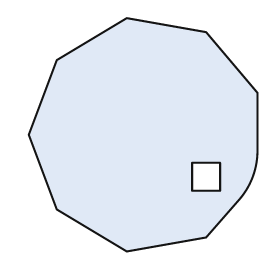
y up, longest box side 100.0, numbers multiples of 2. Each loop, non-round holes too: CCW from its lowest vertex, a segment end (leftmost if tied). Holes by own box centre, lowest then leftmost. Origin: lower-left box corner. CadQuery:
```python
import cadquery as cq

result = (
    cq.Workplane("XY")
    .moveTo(42.0, 0.0)
    .lineTo(76.0, 6.0)
    .lineTo(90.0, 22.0)
    .threePointArc((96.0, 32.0), (98.0, 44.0))
    .lineTo(98.0, 68.0)
    .lineTo(76.0, 94.0)
    .lineTo(42.0, 100.0)
    .lineTo(12.0, 82.0)
    .lineTo(0.0, 50.0)
    .lineTo(12.0, 18.0)
    .close()
    .moveTo(70.0, 26.0)
    .lineTo(82.0, 26.0)
    .lineTo(82.0, 38.0)
    .lineTo(70.0, 38.0)
    .close()
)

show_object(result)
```